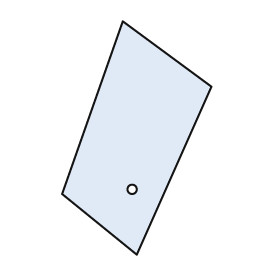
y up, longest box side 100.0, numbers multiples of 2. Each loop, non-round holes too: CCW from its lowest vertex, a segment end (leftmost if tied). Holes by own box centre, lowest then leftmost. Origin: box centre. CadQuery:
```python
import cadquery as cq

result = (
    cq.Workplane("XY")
    .moveTo(0.0, -50.0)
    .lineTo(32.0, 22.0)
    .lineTo(-6.0, 50.0)
    .lineTo(-32.0, -24.0)
    .close()
    .moveTo(-2.0, -22.0)
    .circle(2.0)
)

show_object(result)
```